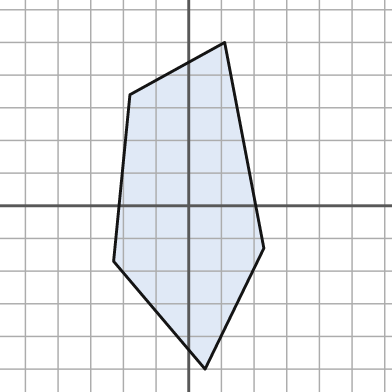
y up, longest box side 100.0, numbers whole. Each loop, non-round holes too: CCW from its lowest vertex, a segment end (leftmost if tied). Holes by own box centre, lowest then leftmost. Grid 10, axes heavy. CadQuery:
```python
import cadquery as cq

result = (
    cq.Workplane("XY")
    .moveTo(5.0, -50.0)
    .lineTo(23.0, -13.0)
    .lineTo(11.0, 50.0)
    .lineTo(-18.0, 34.0)
    .lineTo(-23.0, -17.0)
    .close()
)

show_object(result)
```